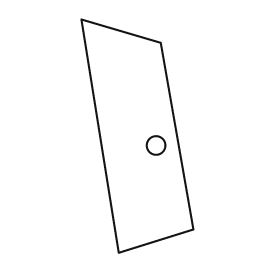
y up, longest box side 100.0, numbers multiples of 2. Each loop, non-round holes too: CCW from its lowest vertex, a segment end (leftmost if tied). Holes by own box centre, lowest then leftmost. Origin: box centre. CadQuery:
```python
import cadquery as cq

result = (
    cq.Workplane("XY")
    .moveTo(-8.0, -50.0)
    .lineTo(24.0, -40.0)
    .lineTo(10.0, 40.0)
    .lineTo(-24.0, 50.0)
    .close()
    .moveTo(8.0, -4.0)
    .circle(4.0)
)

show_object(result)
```